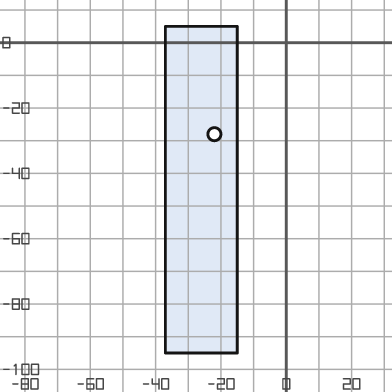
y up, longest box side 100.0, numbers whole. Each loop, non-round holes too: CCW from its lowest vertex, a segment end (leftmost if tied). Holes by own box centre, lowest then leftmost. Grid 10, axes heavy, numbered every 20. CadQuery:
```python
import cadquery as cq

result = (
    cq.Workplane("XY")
    .moveTo(-37.0, -95.0)
    .lineTo(-15.0, -95.0)
    .lineTo(-15.0, 5.0)
    .lineTo(-37.0, 5.0)
    .close()
    .moveTo(-22.0, -28.0)
    .circle(2.0)
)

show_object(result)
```